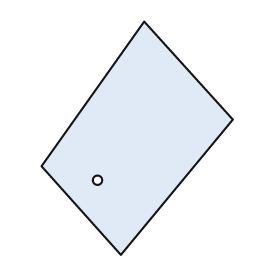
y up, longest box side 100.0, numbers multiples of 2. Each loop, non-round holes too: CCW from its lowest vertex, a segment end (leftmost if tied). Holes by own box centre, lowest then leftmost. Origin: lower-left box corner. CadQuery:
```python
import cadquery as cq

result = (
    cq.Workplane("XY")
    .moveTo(34.0, 0.0)
    .lineTo(82.0, 58.0)
    .lineTo(44.0, 100.0)
    .lineTo(0.0, 38.0)
    .close()
    .moveTo(24.0, 32.0)
    .circle(2.0)
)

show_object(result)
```